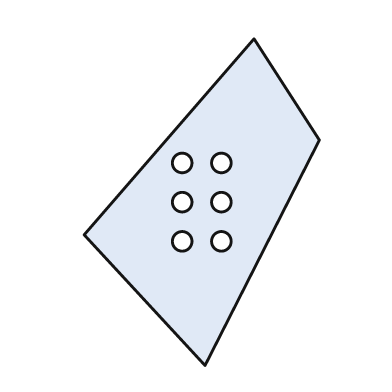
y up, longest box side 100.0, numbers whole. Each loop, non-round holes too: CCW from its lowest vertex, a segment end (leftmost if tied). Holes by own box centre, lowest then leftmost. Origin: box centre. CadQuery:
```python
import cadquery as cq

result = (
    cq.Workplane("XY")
    .moveTo(1.0, -50.0)
    .lineTo(36.0, 19.0)
    .lineTo(16.0, 50.0)
    .lineTo(-36.0, -10.0)
    .close()
    .moveTo(-6.0, -12.0)
    .circle(3.0)
    .moveTo(6.0, -12.0)
    .circle(3.0)
    .moveTo(-6.0, 0.0)
    .circle(3.0)
    .moveTo(6.0, 0.0)
    .circle(3.0)
    .moveTo(-6.0, 12.0)
    .circle(3.0)
    .moveTo(6.0, 12.0)
    .circle(3.0)
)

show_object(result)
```